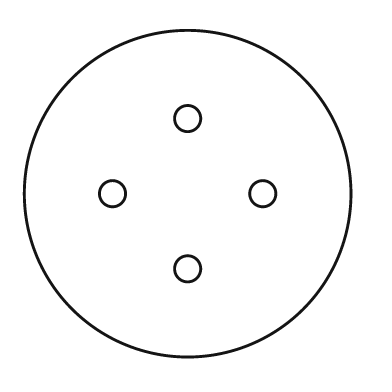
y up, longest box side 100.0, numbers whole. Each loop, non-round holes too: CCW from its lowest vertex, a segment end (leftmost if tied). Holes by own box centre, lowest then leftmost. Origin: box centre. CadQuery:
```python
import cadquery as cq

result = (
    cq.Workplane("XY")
    .moveTo(0.0, 0.0)
    .circle(50.0)
    .moveTo(0.0, -23.0)
    .circle(4.0)
    .moveTo(-23.0, 0.0)
    .circle(4.0)
    .moveTo(23.0, 0.0)
    .circle(4.0)
    .moveTo(0.0, 23.0)
    .circle(4.0)
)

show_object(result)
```